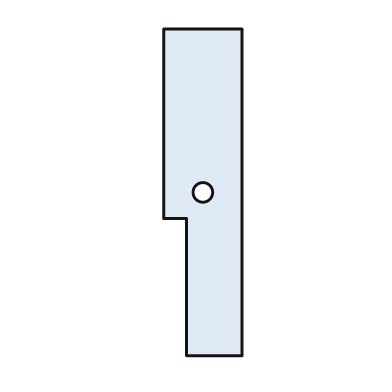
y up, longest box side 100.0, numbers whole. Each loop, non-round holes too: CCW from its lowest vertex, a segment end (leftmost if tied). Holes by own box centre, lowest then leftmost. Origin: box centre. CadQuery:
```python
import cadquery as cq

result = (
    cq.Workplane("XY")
    .moveTo(-5.0, -50.0)
    .lineTo(12.0, -50.0)
    .lineTo(12.0, 50.0)
    .lineTo(-12.0, 50.0)
    .lineTo(-12.0, -8.0)
    .lineTo(-5.0, -8.0)
    .close()
    .moveTo(0.0, 0.0)
    .circle(3.0)
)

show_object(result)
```